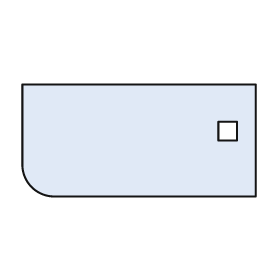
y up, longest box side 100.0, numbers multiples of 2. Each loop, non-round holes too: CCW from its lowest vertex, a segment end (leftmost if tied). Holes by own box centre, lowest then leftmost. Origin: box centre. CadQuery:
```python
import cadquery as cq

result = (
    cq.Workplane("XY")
    .moveTo(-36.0, -24.0)
    .lineTo(50.0, -24.0)
    .lineTo(50.0, 24.0)
    .lineTo(-50.0, 24.0)
    .lineTo(-50.0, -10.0)
    .threePointArc((-46.0, -20.0), (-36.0, -24.0))
    .close()
    .moveTo(34.0, 0.0)
    .lineTo(42.0, 0.0)
    .lineTo(42.0, 8.0)
    .lineTo(34.0, 8.0)
    .close()
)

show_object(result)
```